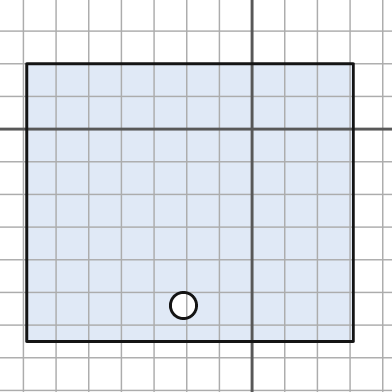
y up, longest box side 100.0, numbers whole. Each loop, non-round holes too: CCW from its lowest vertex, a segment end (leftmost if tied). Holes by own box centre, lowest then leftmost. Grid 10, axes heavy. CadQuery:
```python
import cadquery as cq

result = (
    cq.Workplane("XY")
    .moveTo(-69.0, -65.0)
    .lineTo(31.0, -65.0)
    .lineTo(31.0, 20.0)
    .lineTo(-69.0, 20.0)
    .close()
    .moveTo(-21.0, -54.0)
    .circle(4.0)
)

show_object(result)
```